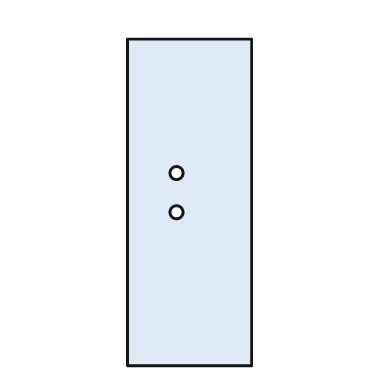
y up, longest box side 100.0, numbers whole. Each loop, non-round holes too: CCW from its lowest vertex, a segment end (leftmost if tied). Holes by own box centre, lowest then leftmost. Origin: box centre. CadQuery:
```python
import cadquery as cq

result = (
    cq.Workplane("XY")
    .moveTo(-19.0, -50.0)
    .lineTo(19.0, -50.0)
    .lineTo(19.0, 50.0)
    .lineTo(-19.0, 50.0)
    .close()
    .moveTo(-4.0, -3.0)
    .circle(2.0)
    .moveTo(-4.0, 9.0)
    .circle(2.0)
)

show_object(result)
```